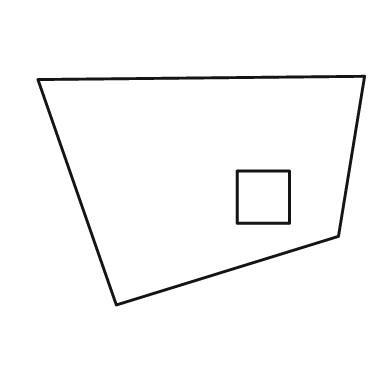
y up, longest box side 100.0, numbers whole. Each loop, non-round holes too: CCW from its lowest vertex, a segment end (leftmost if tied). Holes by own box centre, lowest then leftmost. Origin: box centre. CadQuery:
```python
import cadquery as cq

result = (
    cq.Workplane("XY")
    .moveTo(-26.0, -35.0)
    .lineTo(42.0, -14.0)
    .lineTo(50.0, 35.0)
    .lineTo(-50.0, 34.0)
    .close()
    .moveTo(11.0, -10.0)
    .lineTo(27.0, -10.0)
    .lineTo(27.0, 6.0)
    .lineTo(11.0, 6.0)
    .close()
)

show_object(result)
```